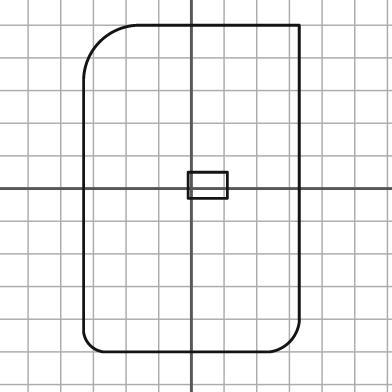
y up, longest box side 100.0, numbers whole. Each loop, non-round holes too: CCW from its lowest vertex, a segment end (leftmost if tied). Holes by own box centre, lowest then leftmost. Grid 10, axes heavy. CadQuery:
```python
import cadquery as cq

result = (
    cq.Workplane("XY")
    .moveTo(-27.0, -50.0)
    .lineTo(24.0, -50.0)
    .threePointArc((30.0, -47.0), (33.0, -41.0))
    .lineTo(33.0, 50.0)
    .lineTo(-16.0, 50.0)
    .threePointArc((-28.0, 45.0), (-33.0, 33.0))
    .lineTo(-33.0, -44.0)
    .threePointArc((-31.0, -48.0), (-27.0, -50.0))
    .close()
    .moveTo(-1.0, -3.0)
    .lineTo(11.0, -3.0)
    .lineTo(11.0, 5.0)
    .lineTo(-1.0, 5.0)
    .close()
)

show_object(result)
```